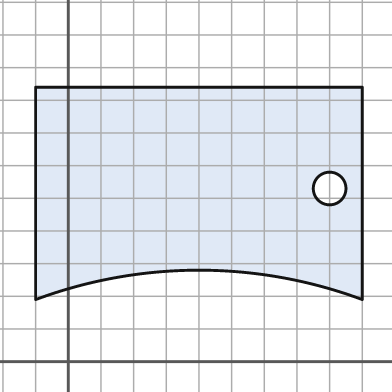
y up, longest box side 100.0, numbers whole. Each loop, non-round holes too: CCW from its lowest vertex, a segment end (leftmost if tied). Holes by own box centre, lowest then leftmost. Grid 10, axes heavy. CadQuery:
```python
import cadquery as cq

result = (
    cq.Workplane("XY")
    .moveTo(-10.0, 19.0)
    .threePointArc((40.0, 28.0), (90.0, 19.0))
    .lineTo(90.0, 84.0)
    .lineTo(-10.0, 84.0)
    .close()
    .moveTo(80.0, 53.0)
    .circle(5.0)
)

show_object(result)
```